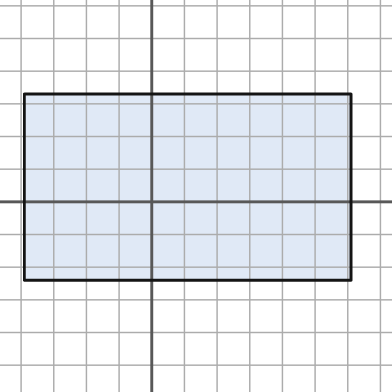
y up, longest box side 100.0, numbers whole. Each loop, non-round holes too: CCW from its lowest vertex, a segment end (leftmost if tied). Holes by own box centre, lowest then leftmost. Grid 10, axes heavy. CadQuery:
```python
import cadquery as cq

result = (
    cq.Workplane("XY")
    .moveTo(-39.0, -24.0)
    .lineTo(61.0, -24.0)
    .lineTo(61.0, 33.0)
    .lineTo(-39.0, 33.0)
    .close()
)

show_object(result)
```